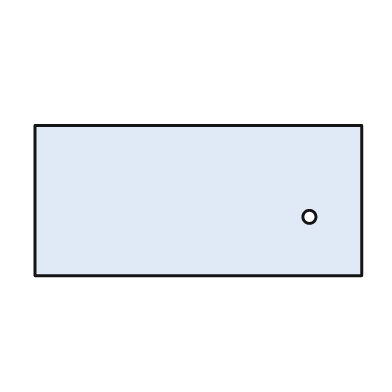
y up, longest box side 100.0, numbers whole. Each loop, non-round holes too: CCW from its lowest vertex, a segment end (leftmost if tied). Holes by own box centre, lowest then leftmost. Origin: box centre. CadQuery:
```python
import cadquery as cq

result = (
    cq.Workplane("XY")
    .moveTo(-50.0, -23.0)
    .lineTo(50.0, -23.0)
    .lineTo(50.0, 23.0)
    .lineTo(-50.0, 23.0)
    .close()
    .moveTo(34.0, -5.0)
    .circle(2.0)
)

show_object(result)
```